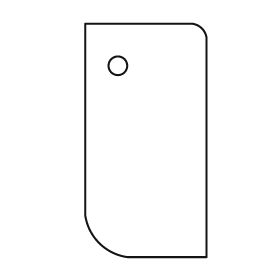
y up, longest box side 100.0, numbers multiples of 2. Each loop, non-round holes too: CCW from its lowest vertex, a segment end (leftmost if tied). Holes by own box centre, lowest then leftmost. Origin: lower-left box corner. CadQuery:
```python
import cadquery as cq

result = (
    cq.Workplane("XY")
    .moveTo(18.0, 0.0)
    .lineTo(52.0, 0.0)
    .lineTo(52.0, 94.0)
    .threePointArc((50.0, 98.0), (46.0, 100.0))
    .lineTo(0.0, 100.0)
    .lineTo(0.0, 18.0)
    .threePointArc((6.0, 6.0), (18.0, 0.0))
    .close()
    .moveTo(14.0, 82.0)
    .circle(4.0)
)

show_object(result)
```